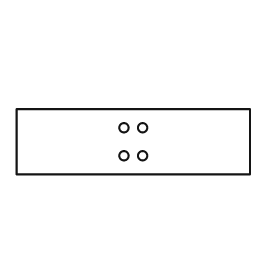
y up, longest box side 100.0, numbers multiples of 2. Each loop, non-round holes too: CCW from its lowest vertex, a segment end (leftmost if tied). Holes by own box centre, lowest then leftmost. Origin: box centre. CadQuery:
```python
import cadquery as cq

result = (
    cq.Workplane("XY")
    .moveTo(-50.0, -14.0)
    .lineTo(50.0, -14.0)
    .lineTo(50.0, 14.0)
    .lineTo(-50.0, 14.0)
    .close()
    .moveTo(-4.0, -6.0)
    .circle(2.0)
    .moveTo(4.0, -6.0)
    .circle(2.0)
    .moveTo(-4.0, 6.0)
    .circle(2.0)
    .moveTo(4.0, 6.0)
    .circle(2.0)
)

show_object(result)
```